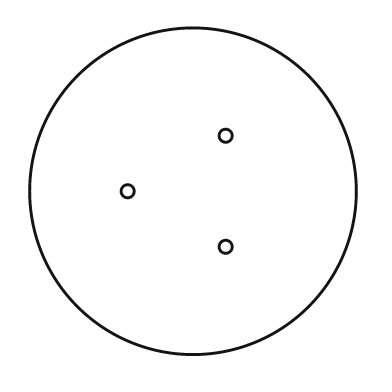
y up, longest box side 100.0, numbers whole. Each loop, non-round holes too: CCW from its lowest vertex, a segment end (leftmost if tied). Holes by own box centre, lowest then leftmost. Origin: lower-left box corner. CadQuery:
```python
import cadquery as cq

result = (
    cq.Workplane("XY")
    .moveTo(50.0, 50.0)
    .circle(50.0)
    .moveTo(60.0, 33.0)
    .circle(2.0)
    .moveTo(30.0, 50.0)
    .circle(2.0)
    .moveTo(60.0, 67.0)
    .circle(2.0)
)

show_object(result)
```